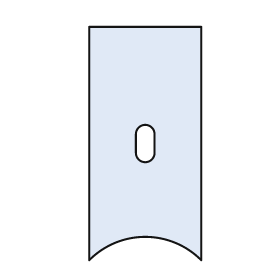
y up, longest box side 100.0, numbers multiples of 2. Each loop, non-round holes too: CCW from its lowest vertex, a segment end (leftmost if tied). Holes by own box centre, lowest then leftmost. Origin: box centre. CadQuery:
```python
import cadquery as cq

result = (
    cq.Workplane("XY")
    .moveTo(-24.0, -50.0)
    .threePointArc((0.0, -40.0), (24.0, -50.0))
    .lineTo(24.0, 50.0)
    .lineTo(-24.0, 50.0)
    .close()
    .moveTo(-4.0, -4.0)
    .threePointArc((0.0, -8.0), (4.0, -4.0))
    .lineTo(4.0, 4.0)
    .threePointArc((0.0, 8.0), (-4.0, 4.0))
    .close()
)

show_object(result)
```